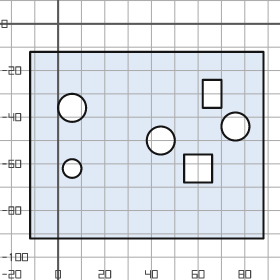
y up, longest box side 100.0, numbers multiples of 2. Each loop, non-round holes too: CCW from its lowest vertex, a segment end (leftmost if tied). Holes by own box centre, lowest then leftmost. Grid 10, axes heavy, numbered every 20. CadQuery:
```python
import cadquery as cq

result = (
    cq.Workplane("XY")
    .moveTo(-12.0, -92.0)
    .lineTo(88.0, -92.0)
    .lineTo(88.0, -12.0)
    .lineTo(-12.0, -12.0)
    .close()
    .moveTo(6.0, -62.0)
    .circle(4.0)
    .moveTo(54.0, -68.0)
    .lineTo(66.0, -68.0)
    .lineTo(66.0, -56.0)
    .lineTo(54.0, -56.0)
    .close()
    .moveTo(44.0, -50.0)
    .circle(6.0)
    .moveTo(76.0, -44.0)
    .circle(6.0)
    .moveTo(6.0, -36.0)
    .circle(6.0)
    .moveTo(62.0, -36.0)
    .lineTo(70.0, -36.0)
    .lineTo(70.0, -24.0)
    .lineTo(62.0, -24.0)
    .close()
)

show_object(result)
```